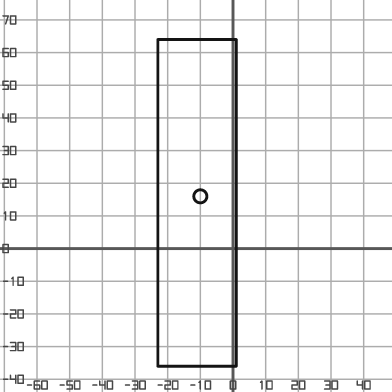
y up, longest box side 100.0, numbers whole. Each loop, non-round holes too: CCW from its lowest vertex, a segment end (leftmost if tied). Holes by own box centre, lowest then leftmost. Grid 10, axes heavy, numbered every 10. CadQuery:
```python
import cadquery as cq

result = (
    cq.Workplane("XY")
    .moveTo(-23.0, -36.0)
    .lineTo(1.0, -36.0)
    .lineTo(1.0, 64.0)
    .lineTo(-23.0, 64.0)
    .close()
    .moveTo(-10.0, 16.0)
    .circle(2.0)
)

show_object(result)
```